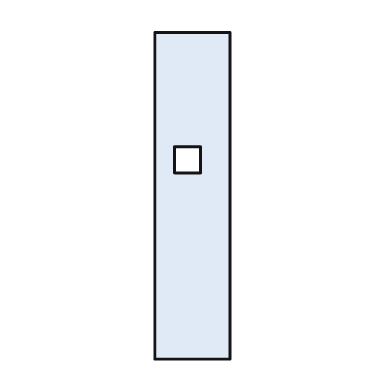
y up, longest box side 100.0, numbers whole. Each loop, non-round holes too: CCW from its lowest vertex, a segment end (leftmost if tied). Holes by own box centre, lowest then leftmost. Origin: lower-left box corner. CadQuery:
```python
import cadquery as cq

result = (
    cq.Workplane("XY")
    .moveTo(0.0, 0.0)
    .lineTo(23.0, 0.0)
    .lineTo(23.0, 100.0)
    .lineTo(0.0, 100.0)
    .close()
    .moveTo(6.0, 57.0)
    .lineTo(14.0, 57.0)
    .lineTo(14.0, 65.0)
    .lineTo(6.0, 65.0)
    .close()
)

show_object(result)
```